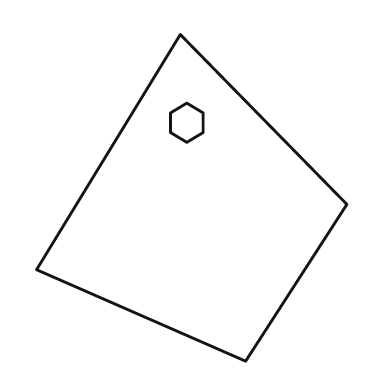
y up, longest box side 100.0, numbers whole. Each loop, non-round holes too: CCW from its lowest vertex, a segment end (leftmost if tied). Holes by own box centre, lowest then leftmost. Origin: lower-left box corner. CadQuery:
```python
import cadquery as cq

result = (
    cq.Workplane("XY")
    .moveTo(64.0, 0.0)
    .lineTo(95.0, 48.0)
    .lineTo(44.0, 100.0)
    .lineTo(0.0, 28.0)
    .close()
    .moveTo(46.0, 67.0)
    .lineTo(51.0, 70.0)
    .lineTo(51.0, 76.0)
    .lineTo(46.0, 79.0)
    .lineTo(41.0, 76.0)
    .lineTo(41.0, 70.0)
    .close()
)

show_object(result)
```